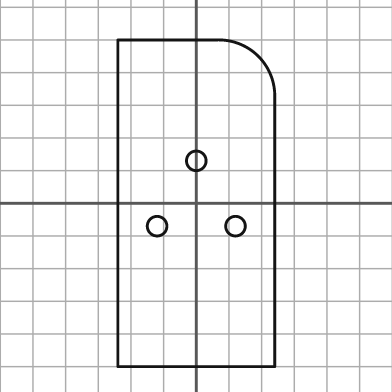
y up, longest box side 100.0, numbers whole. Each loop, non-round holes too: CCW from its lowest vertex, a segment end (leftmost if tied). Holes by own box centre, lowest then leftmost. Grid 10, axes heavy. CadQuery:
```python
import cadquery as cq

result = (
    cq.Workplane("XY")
    .moveTo(-24.0, -50.0)
    .lineTo(24.0, -50.0)
    .lineTo(24.0, 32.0)
    .threePointArc((19.0, 45.0), (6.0, 50.0))
    .lineTo(-24.0, 50.0)
    .close()
    .moveTo(-12.0, -7.0)
    .circle(3.0)
    .moveTo(12.0, -7.0)
    .circle(3.0)
    .moveTo(0.0, 13.0)
    .circle(3.0)
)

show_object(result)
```